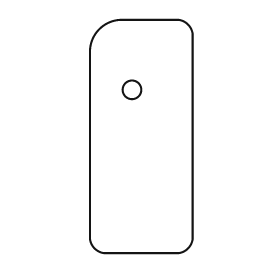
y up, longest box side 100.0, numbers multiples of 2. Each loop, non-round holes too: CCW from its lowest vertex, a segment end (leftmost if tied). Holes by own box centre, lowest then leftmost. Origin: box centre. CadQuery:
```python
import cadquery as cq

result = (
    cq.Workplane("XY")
    .moveTo(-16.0, -50.0)
    .lineTo(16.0, -50.0)
    .threePointArc((20.0, -48.0), (22.0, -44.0))
    .lineTo(22.0, 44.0)
    .threePointArc((20.0, 48.0), (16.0, 50.0))
    .lineTo(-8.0, 50.0)
    .threePointArc((-18.0, 46.0), (-22.0, 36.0))
    .lineTo(-22.0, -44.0)
    .threePointArc((-20.0, -48.0), (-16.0, -50.0))
    .close()
    .moveTo(-4.0, 20.0)
    .circle(4.0)
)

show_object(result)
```